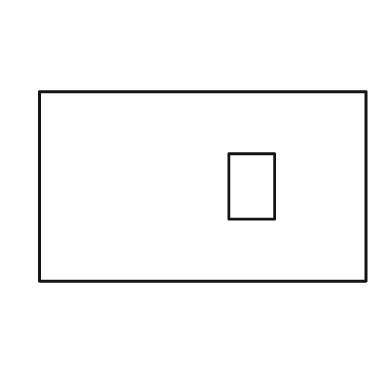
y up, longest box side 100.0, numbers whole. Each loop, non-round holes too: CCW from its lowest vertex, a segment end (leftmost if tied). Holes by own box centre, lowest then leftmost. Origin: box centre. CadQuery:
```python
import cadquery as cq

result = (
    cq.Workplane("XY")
    .moveTo(-50.0, -29.0)
    .lineTo(50.0, -29.0)
    .lineTo(50.0, 29.0)
    .lineTo(-50.0, 29.0)
    .close()
    .moveTo(8.0, -10.0)
    .lineTo(22.0, -10.0)
    .lineTo(22.0, 10.0)
    .lineTo(8.0, 10.0)
    .close()
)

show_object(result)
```